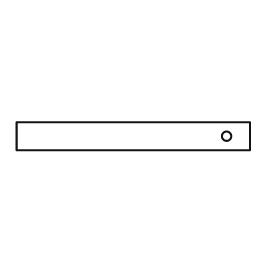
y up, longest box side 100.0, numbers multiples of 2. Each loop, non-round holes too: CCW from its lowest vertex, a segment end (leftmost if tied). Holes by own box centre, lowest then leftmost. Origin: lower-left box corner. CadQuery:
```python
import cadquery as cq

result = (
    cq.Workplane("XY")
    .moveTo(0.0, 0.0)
    .lineTo(100.0, 0.0)
    .lineTo(100.0, 12.0)
    .lineTo(0.0, 12.0)
    .close()
    .moveTo(90.0, 6.0)
    .circle(2.0)
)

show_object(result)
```